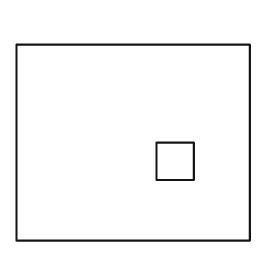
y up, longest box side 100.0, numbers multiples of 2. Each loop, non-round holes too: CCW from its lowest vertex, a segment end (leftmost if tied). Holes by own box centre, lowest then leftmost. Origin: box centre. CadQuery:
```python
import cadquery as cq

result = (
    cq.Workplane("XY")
    .moveTo(-50.0, -42.0)
    .lineTo(50.0, -42.0)
    .lineTo(50.0, 42.0)
    .lineTo(-50.0, 42.0)
    .close()
    .moveTo(10.0, -16.0)
    .lineTo(26.0, -16.0)
    .lineTo(26.0, 0.0)
    .lineTo(10.0, 0.0)
    .close()
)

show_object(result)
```